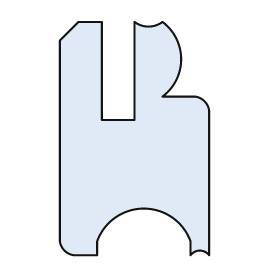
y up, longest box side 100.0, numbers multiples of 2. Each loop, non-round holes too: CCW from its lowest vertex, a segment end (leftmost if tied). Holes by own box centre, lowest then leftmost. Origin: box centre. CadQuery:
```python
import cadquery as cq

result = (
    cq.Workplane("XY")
    .moveTo(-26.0, -50.0)
    .lineTo(-16.0, -50.0)
    .lineTo(-16.0, -44.0)
    .threePointArc((4.0, -30.0), (24.0, -44.0))
    .lineTo(24.0, -50.0)
    .threePointArc((28.0, -48.0), (32.0, -50.0))
    .lineTo(32.0, 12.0)
    .threePointArc((30.0, 16.0), (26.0, 18.0))
    .lineTo(12.0, 18.0)
    .threePointArc((20.0, 34.0), (12.0, 50.0))
    .threePointArc((6.0, 48.0), (0.0, 50.0))
    .lineTo(0.0, 8.0)
    .lineTo(-14.0, 8.0)
    .lineTo(-14.0, 50.0)
    .lineTo(-24.0, 50.0)
    .lineTo(-32.0, 42.0)
    .lineTo(-32.0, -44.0)
    .threePointArc((-30.0, -48.0), (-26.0, -50.0))
    .close()
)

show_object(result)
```